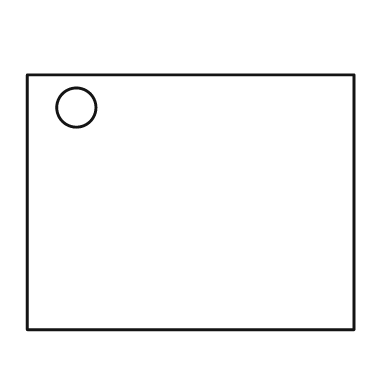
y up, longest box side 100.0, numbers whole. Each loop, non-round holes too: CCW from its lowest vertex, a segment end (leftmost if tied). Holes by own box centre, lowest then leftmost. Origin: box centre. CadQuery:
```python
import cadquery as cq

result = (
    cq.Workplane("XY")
    .moveTo(-50.0, -39.0)
    .lineTo(50.0, -39.0)
    .lineTo(50.0, 39.0)
    .lineTo(-50.0, 39.0)
    .close()
    .moveTo(-35.0, 29.0)
    .circle(6.0)
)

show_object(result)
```